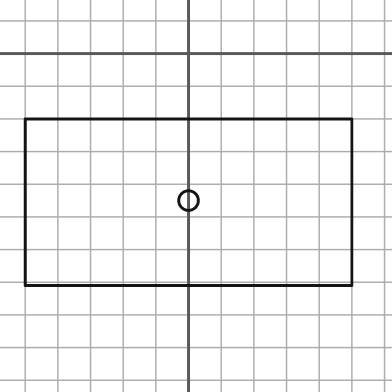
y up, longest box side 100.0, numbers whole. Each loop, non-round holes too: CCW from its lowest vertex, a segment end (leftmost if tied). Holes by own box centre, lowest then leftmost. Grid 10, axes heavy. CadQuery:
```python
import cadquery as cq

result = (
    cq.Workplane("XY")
    .moveTo(-50.0, -71.0)
    .lineTo(50.0, -71.0)
    .lineTo(50.0, -20.0)
    .lineTo(-50.0, -20.0)
    .close()
    .moveTo(0.0, -45.0)
    .circle(3.0)
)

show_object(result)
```